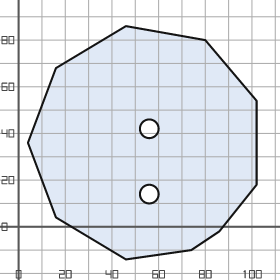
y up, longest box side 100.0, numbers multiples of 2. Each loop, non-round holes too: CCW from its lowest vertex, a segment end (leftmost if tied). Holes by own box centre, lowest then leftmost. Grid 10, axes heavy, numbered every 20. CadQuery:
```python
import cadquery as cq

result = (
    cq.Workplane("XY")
    .moveTo(46.0, -14.0)
    .lineTo(74.0, -10.0)
    .lineTo(86.0, -2.0)
    .lineTo(102.0, 18.0)
    .lineTo(102.0, 54.0)
    .lineTo(80.0, 80.0)
    .lineTo(46.0, 86.0)
    .lineTo(16.0, 68.0)
    .lineTo(4.0, 36.0)
    .lineTo(16.0, 4.0)
    .close()
    .moveTo(56.0, 14.0)
    .circle(4.0)
    .moveTo(56.0, 42.0)
    .circle(4.0)
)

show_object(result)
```